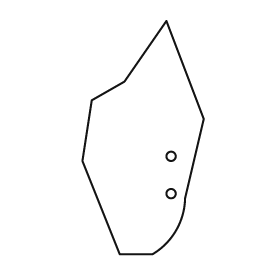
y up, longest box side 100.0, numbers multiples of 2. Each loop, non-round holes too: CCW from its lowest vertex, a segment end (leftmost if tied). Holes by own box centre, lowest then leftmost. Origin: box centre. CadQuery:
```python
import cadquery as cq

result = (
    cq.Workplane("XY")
    .moveTo(-10.0, -50.0)
    .lineTo(4.0, -50.0)
    .threePointArc((14.0, -40.0), (18.0, -26.0))
    .lineTo(26.0, 8.0)
    .lineTo(10.0, 50.0)
    .lineTo(-8.0, 24.0)
    .lineTo(-22.0, 16.0)
    .lineTo(-26.0, -10.0)
    .close()
    .moveTo(12.0, -24.0)
    .circle(2.0)
    .moveTo(12.0, -8.0)
    .circle(2.0)
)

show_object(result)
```